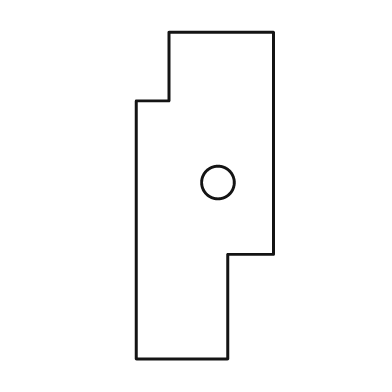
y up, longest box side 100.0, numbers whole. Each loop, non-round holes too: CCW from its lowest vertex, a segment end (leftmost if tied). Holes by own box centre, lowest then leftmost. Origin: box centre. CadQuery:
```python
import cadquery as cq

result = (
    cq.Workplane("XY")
    .moveTo(-21.0, -50.0)
    .lineTo(7.0, -50.0)
    .lineTo(7.0, -18.0)
    .lineTo(21.0, -18.0)
    .lineTo(21.0, 50.0)
    .lineTo(-11.0, 50.0)
    .lineTo(-11.0, 29.0)
    .lineTo(-21.0, 29.0)
    .close()
    .moveTo(4.0, 4.0)
    .circle(5.0)
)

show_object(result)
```